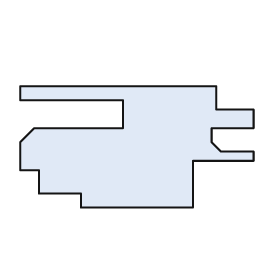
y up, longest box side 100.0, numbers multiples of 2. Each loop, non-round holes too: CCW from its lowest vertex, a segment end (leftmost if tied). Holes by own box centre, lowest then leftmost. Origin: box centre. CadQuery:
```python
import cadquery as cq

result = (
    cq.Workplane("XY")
    .moveTo(-24.0, -26.0)
    .lineTo(24.0, -26.0)
    .lineTo(24.0, -6.0)
    .lineTo(50.0, -6.0)
    .lineTo(50.0, -2.0)
    .lineTo(36.0, -2.0)
    .lineTo(32.0, 2.0)
    .lineTo(32.0, 8.0)
    .lineTo(50.0, 8.0)
    .lineTo(50.0, 16.0)
    .lineTo(34.0, 16.0)
    .lineTo(34.0, 26.0)
    .lineTo(-50.0, 26.0)
    .lineTo(-50.0, 20.0)
    .lineTo(-6.0, 20.0)
    .lineTo(-6.0, 8.0)
    .lineTo(-44.0, 8.0)
    .lineTo(-50.0, 2.0)
    .lineTo(-50.0, -10.0)
    .lineTo(-42.0, -10.0)
    .lineTo(-42.0, -20.0)
    .lineTo(-24.0, -20.0)
    .close()
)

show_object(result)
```